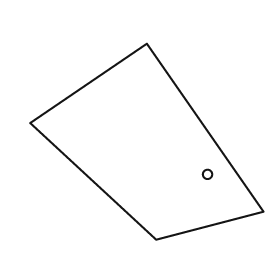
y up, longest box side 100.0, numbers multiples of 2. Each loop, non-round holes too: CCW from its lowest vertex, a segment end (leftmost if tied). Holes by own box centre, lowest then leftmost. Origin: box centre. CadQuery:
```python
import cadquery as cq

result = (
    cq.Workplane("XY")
    .moveTo(4.0, -42.0)
    .lineTo(50.0, -30.0)
    .lineTo(0.0, 42.0)
    .lineTo(-50.0, 8.0)
    .close()
    .moveTo(26.0, -14.0)
    .circle(2.0)
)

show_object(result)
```